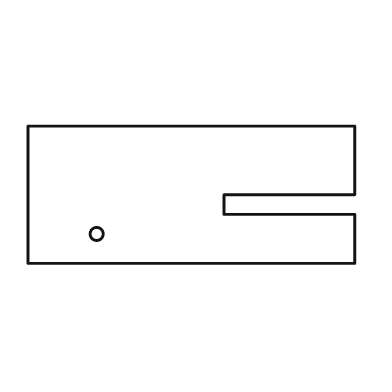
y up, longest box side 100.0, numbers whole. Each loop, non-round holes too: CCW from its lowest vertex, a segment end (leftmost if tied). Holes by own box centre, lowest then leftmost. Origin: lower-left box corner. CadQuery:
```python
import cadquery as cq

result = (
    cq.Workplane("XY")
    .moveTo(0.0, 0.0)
    .lineTo(100.0, 0.0)
    .lineTo(100.0, 15.0)
    .lineTo(60.0, 15.0)
    .lineTo(60.0, 21.0)
    .lineTo(100.0, 21.0)
    .lineTo(100.0, 42.0)
    .lineTo(0.0, 42.0)
    .close()
    .moveTo(21.0, 9.0)
    .circle(2.0)
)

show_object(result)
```